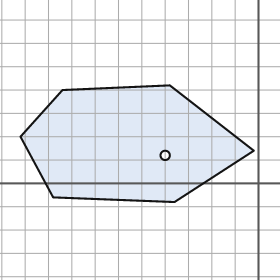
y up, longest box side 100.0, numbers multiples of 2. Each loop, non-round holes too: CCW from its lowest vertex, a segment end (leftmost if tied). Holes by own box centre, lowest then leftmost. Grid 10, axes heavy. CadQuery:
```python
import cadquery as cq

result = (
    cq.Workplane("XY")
    .moveTo(-36.0, -8.0)
    .lineTo(-2.0, 14.0)
    .lineTo(-38.0, 42.0)
    .lineTo(-84.0, 40.0)
    .lineTo(-102.0, 20.0)
    .lineTo(-88.0, -6.0)
    .close()
    .moveTo(-40.0, 12.0)
    .circle(2.0)
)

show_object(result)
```